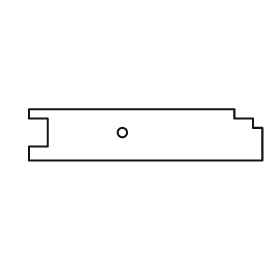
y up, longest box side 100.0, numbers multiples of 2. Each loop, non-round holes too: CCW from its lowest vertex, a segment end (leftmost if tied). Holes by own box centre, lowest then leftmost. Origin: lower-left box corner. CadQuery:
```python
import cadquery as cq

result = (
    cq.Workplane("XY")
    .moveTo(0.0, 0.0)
    .lineTo(100.0, 0.0)
    .lineTo(100.0, 14.0)
    .lineTo(96.0, 14.0)
    .lineTo(96.0, 18.0)
    .lineTo(88.0, 18.0)
    .lineTo(88.0, 22.0)
    .lineTo(0.0, 22.0)
    .lineTo(0.0, 18.0)
    .lineTo(8.0, 18.0)
    .lineTo(8.0, 6.0)
    .lineTo(0.0, 6.0)
    .close()
    .moveTo(40.0, 12.0)
    .circle(2.0)
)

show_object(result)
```